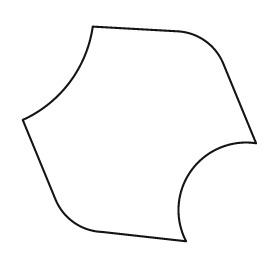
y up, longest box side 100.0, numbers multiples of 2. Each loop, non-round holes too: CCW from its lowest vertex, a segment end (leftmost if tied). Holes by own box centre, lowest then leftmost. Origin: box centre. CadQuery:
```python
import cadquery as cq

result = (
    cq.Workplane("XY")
    .moveTo(20.0, -46.0)
    .threePointArc((22.0, -16.0), (50.0, -4.0))
    .lineTo(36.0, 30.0)
    .threePointArc((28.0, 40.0), (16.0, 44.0))
    .lineTo(-20.0, 46.0)
    .threePointArc((-30.0, 22.0), (-50.0, 6.0))
    .lineTo(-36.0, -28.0)
    .threePointArc((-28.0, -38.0), (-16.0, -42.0))
    .close()
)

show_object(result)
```